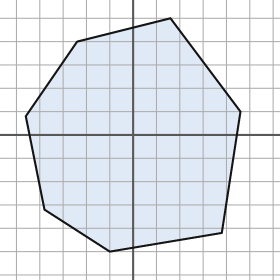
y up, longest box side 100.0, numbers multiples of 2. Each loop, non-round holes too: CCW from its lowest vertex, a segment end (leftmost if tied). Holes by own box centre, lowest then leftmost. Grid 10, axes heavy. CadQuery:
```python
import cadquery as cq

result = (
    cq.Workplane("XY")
    .moveTo(-10.0, -50.0)
    .lineTo(38.0, -42.0)
    .lineTo(46.0, 10.0)
    .lineTo(16.0, 50.0)
    .lineTo(-24.0, 40.0)
    .lineTo(-46.0, 8.0)
    .lineTo(-38.0, -32.0)
    .close()
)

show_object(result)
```